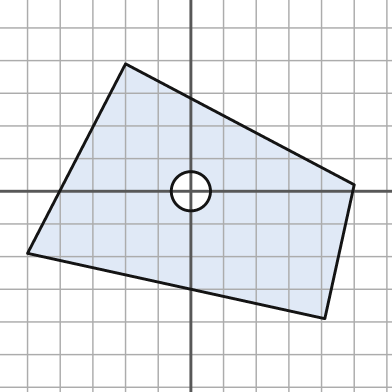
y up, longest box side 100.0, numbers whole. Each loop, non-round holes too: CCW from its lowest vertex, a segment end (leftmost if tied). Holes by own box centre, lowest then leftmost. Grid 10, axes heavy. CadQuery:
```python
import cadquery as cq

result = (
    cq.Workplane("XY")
    .moveTo(41.0, -39.0)
    .lineTo(50.0, 2.0)
    .lineTo(-20.0, 39.0)
    .lineTo(-50.0, -19.0)
    .close()
    .moveTo(0.0, 0.0)
    .circle(6.0)
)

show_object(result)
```